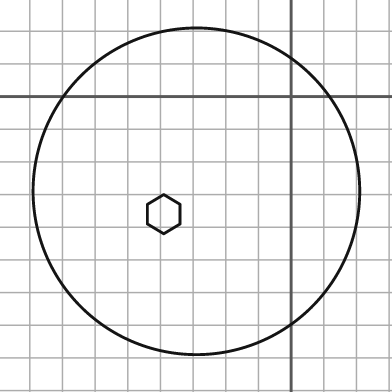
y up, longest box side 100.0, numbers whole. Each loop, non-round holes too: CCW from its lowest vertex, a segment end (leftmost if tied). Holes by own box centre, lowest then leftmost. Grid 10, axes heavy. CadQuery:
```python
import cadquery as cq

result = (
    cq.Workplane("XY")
    .moveTo(-29.0, -29.0)
    .circle(50.0)
    .moveTo(-39.0, -42.0)
    .lineTo(-34.0, -39.0)
    .lineTo(-34.0, -33.0)
    .lineTo(-39.0, -30.0)
    .lineTo(-44.0, -33.0)
    .lineTo(-44.0, -39.0)
    .close()
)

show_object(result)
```